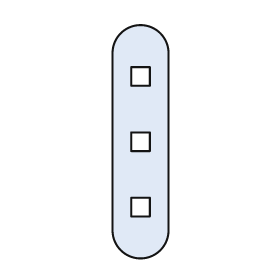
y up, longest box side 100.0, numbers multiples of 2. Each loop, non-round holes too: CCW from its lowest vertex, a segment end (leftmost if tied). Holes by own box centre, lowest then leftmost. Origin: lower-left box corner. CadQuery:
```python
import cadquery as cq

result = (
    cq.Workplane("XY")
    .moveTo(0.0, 12.0)
    .threePointArc((12.0, 0.0), (24.0, 12.0))
    .lineTo(24.0, 88.0)
    .threePointArc((12.0, 100.0), (0.0, 88.0))
    .close()
    .moveTo(8.0, 18.0)
    .lineTo(16.0, 18.0)
    .lineTo(16.0, 26.0)
    .lineTo(8.0, 26.0)
    .close()
    .moveTo(8.0, 46.0)
    .lineTo(16.0, 46.0)
    .lineTo(16.0, 54.0)
    .lineTo(8.0, 54.0)
    .close()
    .moveTo(8.0, 74.0)
    .lineTo(16.0, 74.0)
    .lineTo(16.0, 82.0)
    .lineTo(8.0, 82.0)
    .close()
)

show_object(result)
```